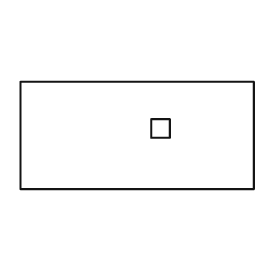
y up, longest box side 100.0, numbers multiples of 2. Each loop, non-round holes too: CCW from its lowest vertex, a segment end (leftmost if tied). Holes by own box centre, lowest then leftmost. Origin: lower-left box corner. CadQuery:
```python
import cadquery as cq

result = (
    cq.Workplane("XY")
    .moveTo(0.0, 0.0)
    .lineTo(100.0, 0.0)
    .lineTo(100.0, 46.0)
    .lineTo(0.0, 46.0)
    .close()
    .moveTo(56.0, 22.0)
    .lineTo(64.0, 22.0)
    .lineTo(64.0, 30.0)
    .lineTo(56.0, 30.0)
    .close()
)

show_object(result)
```